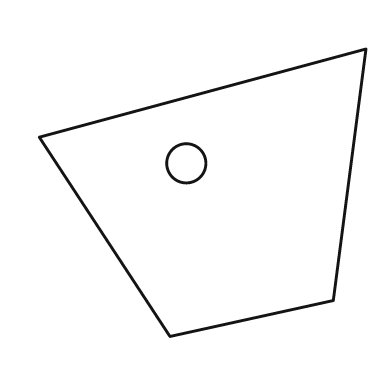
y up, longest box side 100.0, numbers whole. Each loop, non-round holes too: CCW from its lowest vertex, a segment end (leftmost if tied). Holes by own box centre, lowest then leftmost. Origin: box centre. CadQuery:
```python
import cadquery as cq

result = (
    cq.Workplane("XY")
    .moveTo(-10.0, -44.0)
    .lineTo(40.0, -33.0)
    .lineTo(50.0, 44.0)
    .lineTo(-50.0, 17.0)
    .close()
    .moveTo(-5.0, 9.0)
    .circle(6.0)
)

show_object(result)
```